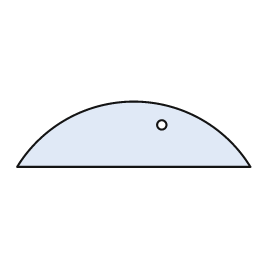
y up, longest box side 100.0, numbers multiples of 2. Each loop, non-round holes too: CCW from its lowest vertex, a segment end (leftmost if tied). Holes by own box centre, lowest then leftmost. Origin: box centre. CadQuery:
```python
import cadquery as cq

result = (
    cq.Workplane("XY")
    .moveTo(-50.0, -14.0)
    .lineTo(50.0, -14.0)
    .threePointArc((0.0, 14.0), (-50.0, -14.0))
    .close()
    .moveTo(12.0, 4.0)
    .circle(2.0)
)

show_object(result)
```